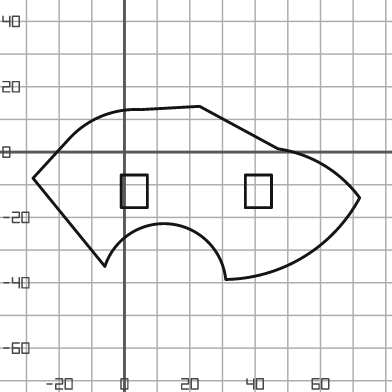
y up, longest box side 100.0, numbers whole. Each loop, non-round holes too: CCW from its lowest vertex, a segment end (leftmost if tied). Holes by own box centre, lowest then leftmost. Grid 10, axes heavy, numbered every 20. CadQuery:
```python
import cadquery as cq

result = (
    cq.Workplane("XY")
    .moveTo(31.0, -39.0)
    .threePointArc((55.0, -32.0), (72.0, -14.0))
    .threePointArc((61.0, -4.0), (47.0, 1.0))
    .lineTo(23.0, 14.0)
    .lineTo(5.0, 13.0)
    .threePointArc((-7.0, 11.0), (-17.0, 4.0))
    .lineTo(-28.0, -8.0)
    .lineTo(-6.0, -35.0)
    .threePointArc((14.0, -22.0), (31.0, -39.0))
    .close()
    .moveTo(-1.0, -17.0)
    .lineTo(7.0, -17.0)
    .lineTo(7.0, -7.0)
    .lineTo(-1.0, -7.0)
    .close()
    .moveTo(37.0, -17.0)
    .lineTo(45.0, -17.0)
    .lineTo(45.0, -7.0)
    .lineTo(37.0, -7.0)
    .close()
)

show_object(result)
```